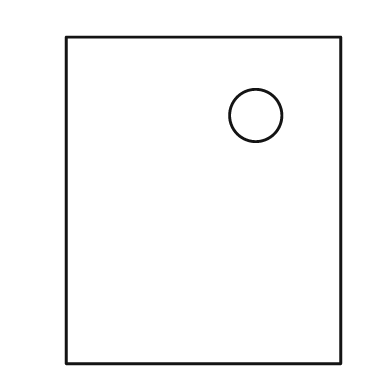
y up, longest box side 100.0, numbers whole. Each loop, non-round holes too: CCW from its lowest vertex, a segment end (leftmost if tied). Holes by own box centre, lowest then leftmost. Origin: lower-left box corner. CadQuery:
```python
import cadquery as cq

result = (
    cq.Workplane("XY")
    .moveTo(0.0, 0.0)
    .lineTo(84.0, 0.0)
    .lineTo(84.0, 100.0)
    .lineTo(0.0, 100.0)
    .close()
    .moveTo(58.0, 76.0)
    .circle(8.0)
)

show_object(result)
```